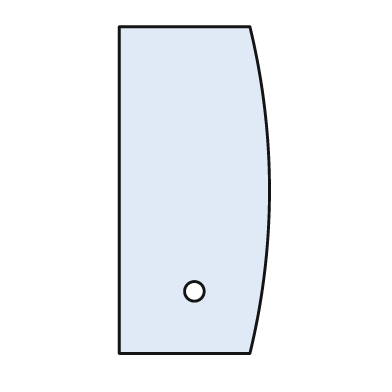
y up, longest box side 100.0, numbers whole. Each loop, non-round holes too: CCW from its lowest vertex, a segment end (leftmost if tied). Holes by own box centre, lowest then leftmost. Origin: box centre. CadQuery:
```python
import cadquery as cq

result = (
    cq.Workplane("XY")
    .moveTo(-23.0, -50.0)
    .lineTo(17.0, -50.0)
    .threePointArc((23.0, 0.0), (17.0, 50.0))
    .lineTo(-23.0, 50.0)
    .close()
    .moveTo(0.0, -31.0)
    .circle(3.0)
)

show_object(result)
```